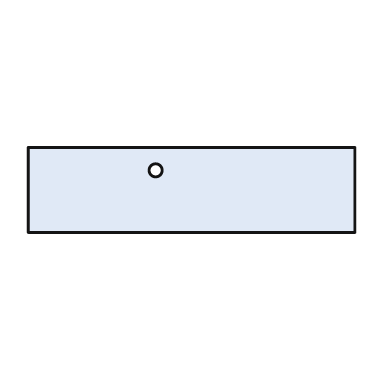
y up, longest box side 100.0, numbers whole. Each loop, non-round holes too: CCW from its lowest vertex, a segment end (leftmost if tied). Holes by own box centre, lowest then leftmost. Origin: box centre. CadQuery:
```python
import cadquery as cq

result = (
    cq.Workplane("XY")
    .moveTo(-50.0, -13.0)
    .lineTo(50.0, -13.0)
    .lineTo(50.0, 13.0)
    .lineTo(-50.0, 13.0)
    .close()
    .moveTo(-11.0, 6.0)
    .circle(2.0)
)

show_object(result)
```